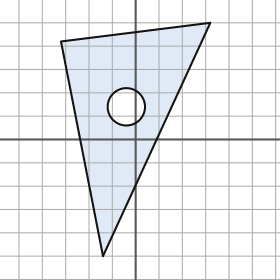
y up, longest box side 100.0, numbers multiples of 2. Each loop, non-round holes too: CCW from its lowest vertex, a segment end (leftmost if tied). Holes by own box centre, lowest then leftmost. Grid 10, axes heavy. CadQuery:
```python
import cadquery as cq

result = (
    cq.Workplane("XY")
    .moveTo(-14.0, -50.0)
    .lineTo(32.0, 50.0)
    .lineTo(-32.0, 42.0)
    .close()
    .moveTo(-4.0, 14.0)
    .circle(8.0)
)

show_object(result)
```